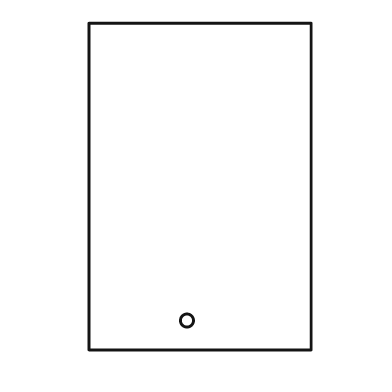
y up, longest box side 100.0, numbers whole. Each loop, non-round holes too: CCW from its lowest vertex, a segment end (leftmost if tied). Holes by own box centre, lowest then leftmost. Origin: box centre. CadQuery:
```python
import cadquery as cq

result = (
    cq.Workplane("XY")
    .moveTo(-34.0, -50.0)
    .lineTo(34.0, -50.0)
    .lineTo(34.0, 50.0)
    .lineTo(-34.0, 50.0)
    .close()
    .moveTo(-4.0, -41.0)
    .circle(2.0)
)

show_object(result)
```